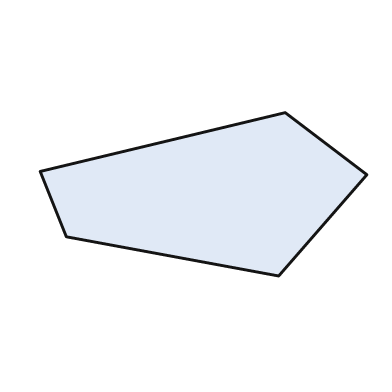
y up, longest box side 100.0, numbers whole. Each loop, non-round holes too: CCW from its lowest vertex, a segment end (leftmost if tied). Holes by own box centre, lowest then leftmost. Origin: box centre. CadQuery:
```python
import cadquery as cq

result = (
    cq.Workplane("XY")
    .moveTo(23.0, -25.0)
    .lineTo(50.0, 6.0)
    .lineTo(25.0, 25.0)
    .lineTo(-50.0, 7.0)
    .lineTo(-42.0, -13.0)
    .close()
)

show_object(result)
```